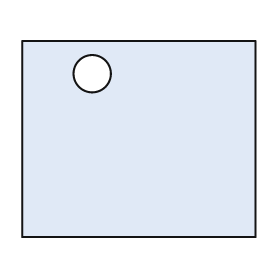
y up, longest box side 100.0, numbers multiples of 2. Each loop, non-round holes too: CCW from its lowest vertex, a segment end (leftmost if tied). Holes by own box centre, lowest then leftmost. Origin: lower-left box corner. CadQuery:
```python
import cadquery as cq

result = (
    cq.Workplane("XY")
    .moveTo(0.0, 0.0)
    .lineTo(100.0, 0.0)
    .lineTo(100.0, 84.0)
    .lineTo(0.0, 84.0)
    .close()
    .moveTo(30.0, 70.0)
    .circle(8.0)
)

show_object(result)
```